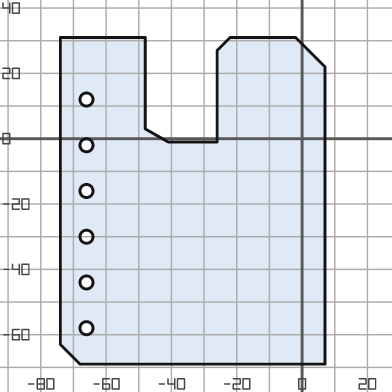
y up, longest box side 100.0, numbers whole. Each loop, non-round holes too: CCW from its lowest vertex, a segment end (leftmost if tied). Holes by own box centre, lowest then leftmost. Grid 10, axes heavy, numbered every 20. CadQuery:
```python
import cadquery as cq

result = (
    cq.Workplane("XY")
    .moveTo(-68.0, -69.0)
    .lineTo(7.0, -69.0)
    .lineTo(7.0, 22.0)
    .lineTo(-2.0, 31.0)
    .lineTo(-22.0, 31.0)
    .lineTo(-26.0, 27.0)
    .lineTo(-26.0, -1.0)
    .lineTo(-41.0, -1.0)
    .lineTo(-48.0, 3.0)
    .lineTo(-48.0, 31.0)
    .lineTo(-74.0, 31.0)
    .lineTo(-74.0, -63.0)
    .close()
    .moveTo(-66.0, -58.0)
    .circle(2.0)
    .moveTo(-66.0, -44.0)
    .circle(2.0)
    .moveTo(-66.0, -30.0)
    .circle(2.0)
    .moveTo(-66.0, -16.0)
    .circle(2.0)
    .moveTo(-66.0, -2.0)
    .circle(2.0)
    .moveTo(-66.0, 12.0)
    .circle(2.0)
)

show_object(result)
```